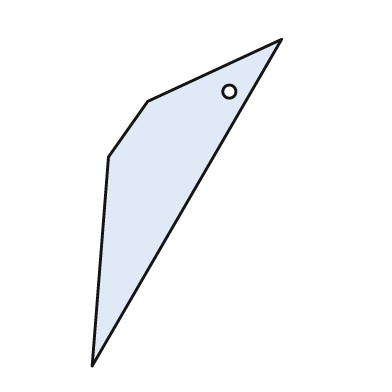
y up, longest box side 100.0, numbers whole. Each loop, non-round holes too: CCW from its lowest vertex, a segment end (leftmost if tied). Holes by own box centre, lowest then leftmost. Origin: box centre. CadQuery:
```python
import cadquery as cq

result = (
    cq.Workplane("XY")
    .moveTo(-29.0, -50.0)
    .lineTo(29.0, 50.0)
    .lineTo(-12.0, 31.0)
    .lineTo(-24.0, 14.0)
    .close()
    .moveTo(13.0, 34.0)
    .circle(2.0)
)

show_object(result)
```